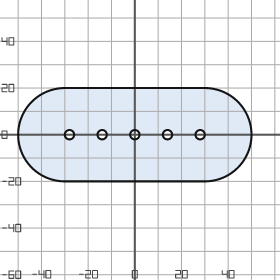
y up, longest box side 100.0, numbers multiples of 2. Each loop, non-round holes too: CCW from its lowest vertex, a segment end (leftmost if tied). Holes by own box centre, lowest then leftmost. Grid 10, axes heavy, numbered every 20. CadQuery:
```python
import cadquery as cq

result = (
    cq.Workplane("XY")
    .moveTo(-30.0, -20.0)
    .lineTo(30.0, -20.0)
    .threePointArc((50.0, 0.0), (30.0, 20.0))
    .lineTo(-30.0, 20.0)
    .threePointArc((-50.0, 0.0), (-30.0, -20.0))
    .close()
    .moveTo(-28.0, 0.0)
    .circle(2.0)
    .moveTo(-14.0, 0.0)
    .circle(2.0)
    .moveTo(0.0, 0.0)
    .circle(2.0)
    .moveTo(14.0, 0.0)
    .circle(2.0)
    .moveTo(28.0, 0.0)
    .circle(2.0)
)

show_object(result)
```